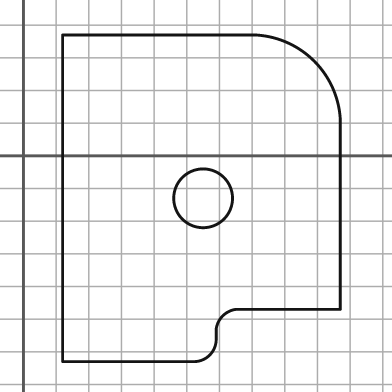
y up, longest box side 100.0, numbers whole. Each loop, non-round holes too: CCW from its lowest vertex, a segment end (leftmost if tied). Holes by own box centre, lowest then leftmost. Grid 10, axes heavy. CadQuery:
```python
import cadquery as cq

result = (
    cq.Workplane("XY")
    .moveTo(12.0, -63.0)
    .lineTo(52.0, -63.0)
    .threePointArc((57.0, -61.0), (59.0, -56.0))
    .lineTo(59.0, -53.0)
    .threePointArc((61.0, -49.0), (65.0, -47.0))
    .lineTo(97.0, -47.0)
    .lineTo(97.0, 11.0)
    .threePointArc((89.0, 29.0), (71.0, 37.0))
    .lineTo(12.0, 37.0)
    .close()
    .moveTo(55.0, -13.0)
    .circle(9.0)
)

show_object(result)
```